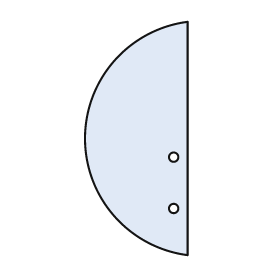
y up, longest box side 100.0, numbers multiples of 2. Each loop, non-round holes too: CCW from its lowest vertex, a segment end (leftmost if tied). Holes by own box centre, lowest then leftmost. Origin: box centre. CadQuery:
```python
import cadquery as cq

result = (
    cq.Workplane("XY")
    .moveTo(22.0, -50.0)
    .lineTo(22.0, 50.0)
    .threePointArc((-22.0, 0.0), (22.0, -50.0))
    .close()
    .moveTo(16.0, -30.0)
    .circle(2.0)
    .moveTo(16.0, -8.0)
    .circle(2.0)
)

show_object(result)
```